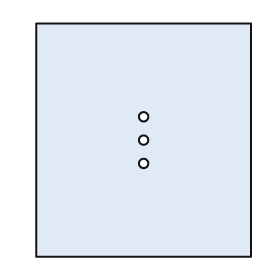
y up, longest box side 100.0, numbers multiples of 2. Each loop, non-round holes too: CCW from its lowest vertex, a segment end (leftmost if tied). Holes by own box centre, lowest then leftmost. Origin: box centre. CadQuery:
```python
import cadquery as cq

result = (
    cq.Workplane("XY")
    .moveTo(-46.0, -50.0)
    .lineTo(46.0, -50.0)
    .lineTo(46.0, 50.0)
    .lineTo(-46.0, 50.0)
    .close()
    .moveTo(0.0, -10.0)
    .circle(2.0)
    .moveTo(0.0, 0.0)
    .circle(2.0)
    .moveTo(0.0, 10.0)
    .circle(2.0)
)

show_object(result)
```